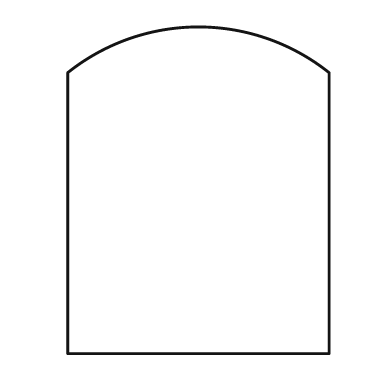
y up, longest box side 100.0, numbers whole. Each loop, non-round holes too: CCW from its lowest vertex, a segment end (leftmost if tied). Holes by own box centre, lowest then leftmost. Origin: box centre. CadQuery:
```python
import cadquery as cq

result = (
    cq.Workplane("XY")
    .moveTo(-40.0, -50.0)
    .lineTo(40.0, -50.0)
    .lineTo(40.0, 36.0)
    .threePointArc((0.0, 50.0), (-40.0, 36.0))
    .close()
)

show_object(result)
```